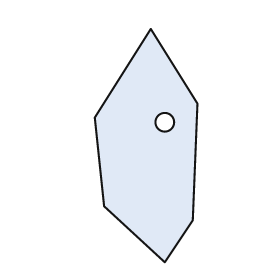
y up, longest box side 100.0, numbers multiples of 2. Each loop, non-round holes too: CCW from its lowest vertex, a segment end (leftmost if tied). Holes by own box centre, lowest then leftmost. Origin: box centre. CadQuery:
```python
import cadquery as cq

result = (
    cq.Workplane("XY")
    .moveTo(8.0, -50.0)
    .lineTo(20.0, -32.0)
    .lineTo(22.0, 18.0)
    .lineTo(2.0, 50.0)
    .lineTo(-22.0, 12.0)
    .lineTo(-18.0, -26.0)
    .close()
    .moveTo(8.0, 10.0)
    .circle(4.0)
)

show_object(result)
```